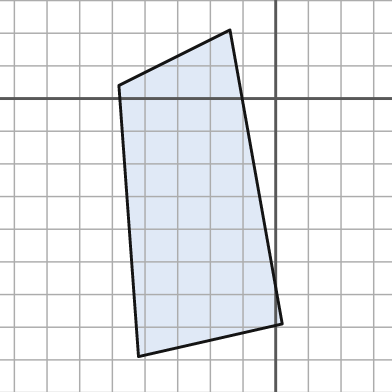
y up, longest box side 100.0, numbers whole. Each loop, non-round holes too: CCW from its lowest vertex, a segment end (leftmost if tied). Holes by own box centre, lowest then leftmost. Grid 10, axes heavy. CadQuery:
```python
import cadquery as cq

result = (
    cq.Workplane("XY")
    .moveTo(-42.0, -79.0)
    .lineTo(2.0, -69.0)
    .lineTo(-14.0, 21.0)
    .lineTo(-48.0, 4.0)
    .close()
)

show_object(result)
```